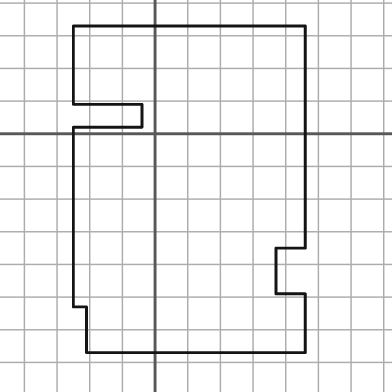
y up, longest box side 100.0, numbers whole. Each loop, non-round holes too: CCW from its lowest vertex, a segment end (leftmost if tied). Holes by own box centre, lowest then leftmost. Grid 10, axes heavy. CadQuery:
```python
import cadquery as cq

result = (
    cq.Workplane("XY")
    .moveTo(-21.0, -67.0)
    .lineTo(46.0, -67.0)
    .lineTo(46.0, -49.0)
    .lineTo(37.0, -49.0)
    .lineTo(37.0, -35.0)
    .lineTo(46.0, -35.0)
    .lineTo(46.0, 33.0)
    .lineTo(-25.0, 33.0)
    .lineTo(-25.0, 9.0)
    .lineTo(-4.0, 9.0)
    .lineTo(-4.0, 2.0)
    .lineTo(-25.0, 2.0)
    .lineTo(-25.0, -53.0)
    .lineTo(-21.0, -53.0)
    .close()
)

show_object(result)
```